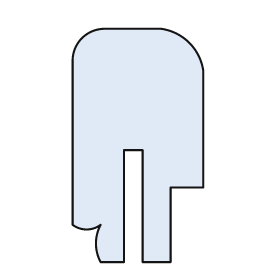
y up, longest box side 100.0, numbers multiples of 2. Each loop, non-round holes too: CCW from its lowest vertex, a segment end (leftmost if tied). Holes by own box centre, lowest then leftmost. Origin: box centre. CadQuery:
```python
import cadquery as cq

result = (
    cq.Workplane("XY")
    .moveTo(-16.0, -50.0)
    .lineTo(-6.0, -50.0)
    .lineTo(-6.0, -2.0)
    .lineTo(2.0, -2.0)
    .lineTo(2.0, -50.0)
    .lineTo(14.0, -50.0)
    .lineTo(14.0, -18.0)
    .lineTo(28.0, -18.0)
    .lineTo(28.0, 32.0)
    .threePointArc((22.0, 44.0), (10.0, 50.0))
    .lineTo(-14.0, 50.0)
    .threePointArc((-24.0, 46.0), (-28.0, 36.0))
    .lineTo(-28.0, -34.0)
    .threePointArc((-22.0, -36.0), (-16.0, -34.0))
    .threePointArc((-18.0, -42.0), (-16.0, -50.0))
    .close()
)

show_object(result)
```